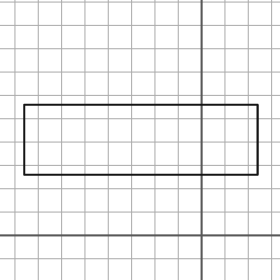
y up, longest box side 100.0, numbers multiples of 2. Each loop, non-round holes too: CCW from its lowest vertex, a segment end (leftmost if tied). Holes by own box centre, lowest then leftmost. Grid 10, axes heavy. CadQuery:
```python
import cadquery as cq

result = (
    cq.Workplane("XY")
    .moveTo(-76.0, 26.0)
    .lineTo(24.0, 26.0)
    .lineTo(24.0, 56.0)
    .lineTo(-76.0, 56.0)
    .close()
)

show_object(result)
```